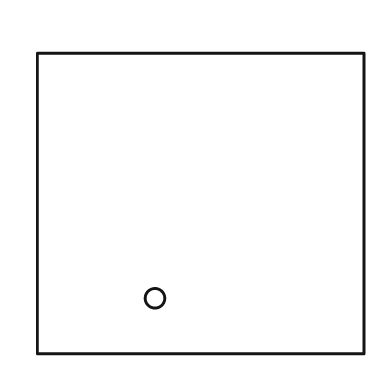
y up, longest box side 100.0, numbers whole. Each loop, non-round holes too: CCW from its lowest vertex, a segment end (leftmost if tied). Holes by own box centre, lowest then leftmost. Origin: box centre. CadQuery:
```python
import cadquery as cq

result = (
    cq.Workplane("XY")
    .moveTo(-50.0, -46.0)
    .lineTo(50.0, -46.0)
    .lineTo(50.0, 46.0)
    .lineTo(-50.0, 46.0)
    .close()
    .moveTo(-14.0, -29.0)
    .circle(3.0)
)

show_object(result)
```